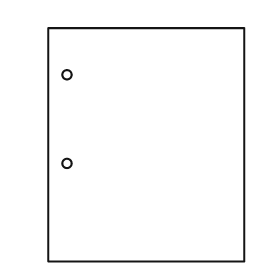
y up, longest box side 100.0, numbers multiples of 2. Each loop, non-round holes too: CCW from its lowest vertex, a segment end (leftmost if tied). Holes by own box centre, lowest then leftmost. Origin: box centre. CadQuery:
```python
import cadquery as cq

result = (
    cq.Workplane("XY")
    .moveTo(-42.0, -50.0)
    .lineTo(42.0, -50.0)
    .lineTo(42.0, 50.0)
    .lineTo(-42.0, 50.0)
    .close()
    .moveTo(-34.0, -8.0)
    .circle(2.0)
    .moveTo(-34.0, 30.0)
    .circle(2.0)
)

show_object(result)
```